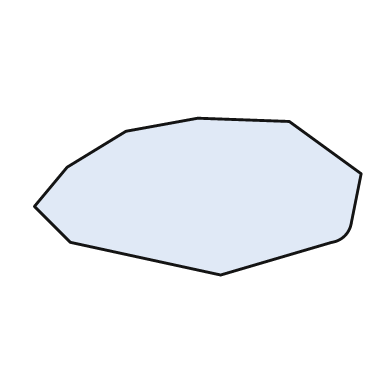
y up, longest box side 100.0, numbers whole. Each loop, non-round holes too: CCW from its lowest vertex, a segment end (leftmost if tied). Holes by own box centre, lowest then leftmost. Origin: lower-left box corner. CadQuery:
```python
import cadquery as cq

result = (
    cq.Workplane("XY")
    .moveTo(57.0, 0.0)
    .lineTo(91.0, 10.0)
    .threePointArc((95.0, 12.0), (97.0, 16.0))
    .lineTo(100.0, 31.0)
    .lineTo(78.0, 47.0)
    .lineTo(50.0, 48.0)
    .lineTo(28.0, 44.0)
    .lineTo(10.0, 33.0)
    .lineTo(0.0, 21.0)
    .lineTo(11.0, 10.0)
    .close()
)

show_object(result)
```